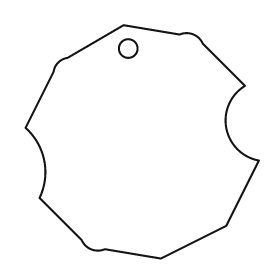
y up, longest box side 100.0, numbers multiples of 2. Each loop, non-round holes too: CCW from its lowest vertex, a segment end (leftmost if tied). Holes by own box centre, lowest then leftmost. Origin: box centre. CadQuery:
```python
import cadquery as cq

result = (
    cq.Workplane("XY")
    .moveTo(8.0, -50.0)
    .lineTo(36.0, -36.0)
    .lineTo(50.0, -8.0)
    .threePointArc((36.0, 6.0), (44.0, 24.0))
    .lineTo(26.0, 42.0)
    .threePointArc((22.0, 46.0), (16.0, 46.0))
    .lineTo(-8.0, 50.0)
    .lineTo(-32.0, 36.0)
    .threePointArc((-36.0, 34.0), (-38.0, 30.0))
    .lineTo(-50.0, 6.0)
    .threePointArc((-42.0, -8.0), (-44.0, -24.0))
    .lineTo(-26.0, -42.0)
    .threePointArc((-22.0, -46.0), (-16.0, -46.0))
    .close()
    .moveTo(-6.0, 40.0)
    .circle(4.0)
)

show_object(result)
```